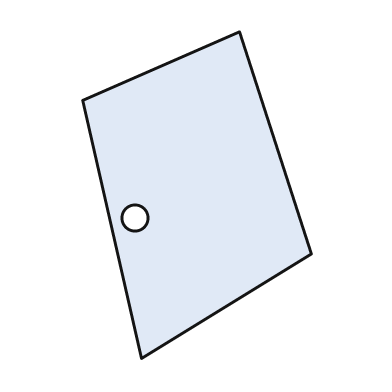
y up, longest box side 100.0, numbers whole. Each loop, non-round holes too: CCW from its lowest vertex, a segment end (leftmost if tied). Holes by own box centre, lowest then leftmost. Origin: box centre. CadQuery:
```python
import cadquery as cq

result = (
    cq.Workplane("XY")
    .moveTo(-17.0, -50.0)
    .lineTo(35.0, -18.0)
    .lineTo(13.0, 50.0)
    .lineTo(-35.0, 29.0)
    .close()
    .moveTo(-19.0, -7.0)
    .circle(4.0)
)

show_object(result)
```